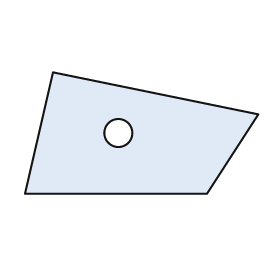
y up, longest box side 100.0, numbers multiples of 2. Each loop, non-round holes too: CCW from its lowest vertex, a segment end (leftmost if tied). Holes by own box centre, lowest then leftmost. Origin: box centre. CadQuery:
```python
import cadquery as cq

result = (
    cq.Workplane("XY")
    .moveTo(-50.0, -26.0)
    .lineTo(28.0, -26.0)
    .lineTo(50.0, 8.0)
    .lineTo(-38.0, 26.0)
    .close()
    .moveTo(-10.0, 0.0)
    .circle(6.0)
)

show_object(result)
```